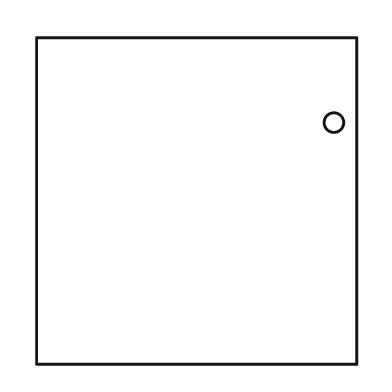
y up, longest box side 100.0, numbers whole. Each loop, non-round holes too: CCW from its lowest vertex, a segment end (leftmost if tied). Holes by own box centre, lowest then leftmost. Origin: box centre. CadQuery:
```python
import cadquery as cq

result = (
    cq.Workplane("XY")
    .moveTo(-49.0, -50.0)
    .lineTo(49.0, -50.0)
    .lineTo(49.0, 50.0)
    .lineTo(-49.0, 50.0)
    .close()
    .moveTo(42.0, 24.0)
    .circle(3.0)
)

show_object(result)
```